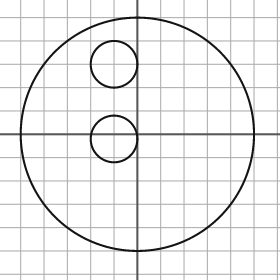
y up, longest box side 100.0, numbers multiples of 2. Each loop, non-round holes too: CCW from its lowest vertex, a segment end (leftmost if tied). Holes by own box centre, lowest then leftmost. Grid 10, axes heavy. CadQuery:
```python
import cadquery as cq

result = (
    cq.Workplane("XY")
    .moveTo(0.0, 0.0)
    .circle(50.0)
    .moveTo(-10.0, -2.0)
    .circle(10.0)
    .moveTo(-10.0, 30.0)
    .circle(10.0)
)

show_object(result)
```